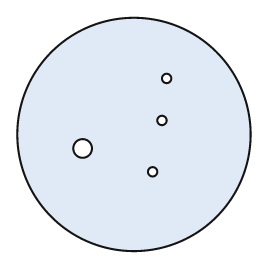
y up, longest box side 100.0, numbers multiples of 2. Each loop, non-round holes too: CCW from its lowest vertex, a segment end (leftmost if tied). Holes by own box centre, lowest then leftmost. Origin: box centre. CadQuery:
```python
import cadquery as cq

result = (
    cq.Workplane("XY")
    .moveTo(0.0, 0.0)
    .circle(50.0)
    .moveTo(8.0, -16.0)
    .circle(2.0)
    .moveTo(-22.0, -6.0)
    .circle(4.0)
    .moveTo(12.0, 6.0)
    .circle(2.0)
    .moveTo(14.0, 24.0)
    .circle(2.0)
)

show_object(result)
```